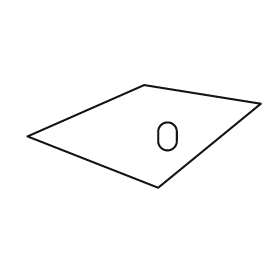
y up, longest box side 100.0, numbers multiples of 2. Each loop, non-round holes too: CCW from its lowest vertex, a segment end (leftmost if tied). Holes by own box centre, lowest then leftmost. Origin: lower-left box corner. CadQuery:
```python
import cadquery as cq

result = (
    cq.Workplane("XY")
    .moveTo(56.0, 0.0)
    .lineTo(100.0, 36.0)
    .lineTo(50.0, 44.0)
    .lineTo(0.0, 22.0)
    .close()
    .moveTo(56.0, 20.0)
    .threePointArc((60.0, 16.0), (64.0, 20.0))
    .lineTo(64.0, 24.0)
    .threePointArc((60.0, 28.0), (56.0, 24.0))
    .close()
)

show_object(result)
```